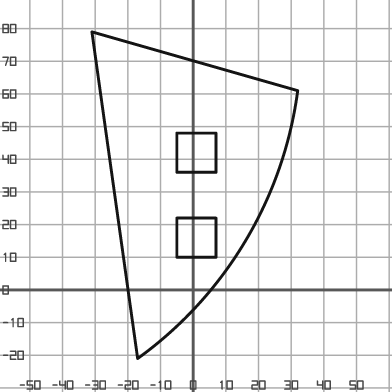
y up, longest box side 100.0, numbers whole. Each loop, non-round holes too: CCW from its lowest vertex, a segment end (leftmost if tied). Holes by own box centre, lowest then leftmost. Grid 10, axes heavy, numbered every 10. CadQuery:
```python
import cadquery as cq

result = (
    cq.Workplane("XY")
    .moveTo(-17.0, -21.0)
    .threePointArc((16.0, 15.0), (32.0, 61.0))
    .lineTo(-31.0, 79.0)
    .close()
    .moveTo(-5.0, 10.0)
    .lineTo(7.0, 10.0)
    .lineTo(7.0, 22.0)
    .lineTo(-5.0, 22.0)
    .close()
    .moveTo(-5.0, 36.0)
    .lineTo(7.0, 36.0)
    .lineTo(7.0, 48.0)
    .lineTo(-5.0, 48.0)
    .close()
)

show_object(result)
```